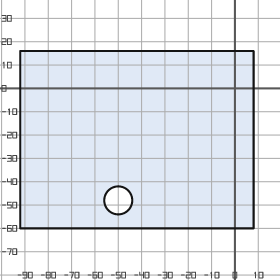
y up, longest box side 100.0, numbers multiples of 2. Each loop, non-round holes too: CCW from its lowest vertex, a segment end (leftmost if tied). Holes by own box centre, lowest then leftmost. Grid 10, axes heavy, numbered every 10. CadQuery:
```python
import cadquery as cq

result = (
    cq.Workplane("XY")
    .moveTo(-92.0, -60.0)
    .lineTo(8.0, -60.0)
    .lineTo(8.0, 16.0)
    .lineTo(-92.0, 16.0)
    .close()
    .moveTo(-50.0, -48.0)
    .circle(6.0)
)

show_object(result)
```